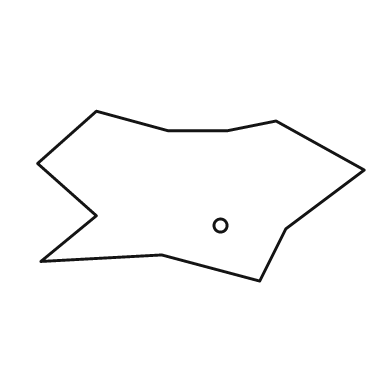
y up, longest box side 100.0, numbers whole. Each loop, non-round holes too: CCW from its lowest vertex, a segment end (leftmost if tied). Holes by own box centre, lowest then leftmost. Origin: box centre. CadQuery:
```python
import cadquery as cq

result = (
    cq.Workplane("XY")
    .moveTo(18.0, -26.0)
    .lineTo(26.0, -10.0)
    .lineTo(50.0, 8.0)
    .lineTo(23.0, 23.0)
    .lineTo(8.0, 20.0)
    .lineTo(-10.0, 20.0)
    .lineTo(-32.0, 26.0)
    .lineTo(-50.0, 10.0)
    .lineTo(-32.0, -6.0)
    .lineTo(-49.0, -20.0)
    .lineTo(-12.0, -18.0)
    .close()
    .moveTo(6.0, -9.0)
    .circle(2.0)
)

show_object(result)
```